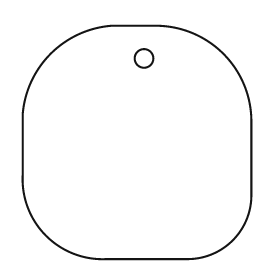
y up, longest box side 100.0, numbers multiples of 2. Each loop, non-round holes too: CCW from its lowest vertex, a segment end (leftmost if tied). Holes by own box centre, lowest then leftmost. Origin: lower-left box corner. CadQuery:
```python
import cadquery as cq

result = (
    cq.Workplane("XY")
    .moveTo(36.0, 0.0)
    .lineTo(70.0, 0.0)
    .threePointArc((90.0, 8.0), (98.0, 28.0))
    .lineTo(98.0, 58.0)
    .threePointArc((86.0, 88.0), (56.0, 100.0))
    .lineTo(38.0, 100.0)
    .threePointArc((12.0, 88.0), (0.0, 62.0))
    .lineTo(0.0, 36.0)
    .threePointArc((10.0, 10.0), (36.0, 0.0))
    .close()
    .moveTo(52.0, 86.0)
    .circle(4.0)
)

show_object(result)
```